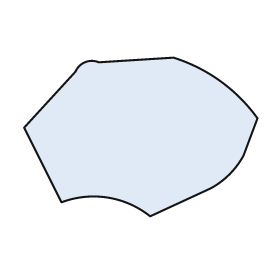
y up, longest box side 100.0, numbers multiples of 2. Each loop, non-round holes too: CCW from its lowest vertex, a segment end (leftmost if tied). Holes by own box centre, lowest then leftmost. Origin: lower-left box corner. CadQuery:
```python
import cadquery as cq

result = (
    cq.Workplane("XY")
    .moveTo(54.0, 0.0)
    .lineTo(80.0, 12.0)
    .threePointArc((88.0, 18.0), (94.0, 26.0))
    .lineTo(100.0, 42.0)
    .threePointArc((84.0, 58.0), (64.0, 68.0))
    .lineTo(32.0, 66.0)
    .threePointArc((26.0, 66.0), (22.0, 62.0))
    .lineTo(0.0, 38.0)
    .lineTo(16.0, 6.0)
    .threePointArc((36.0, 8.0), (54.0, 0.0))
    .close()
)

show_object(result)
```